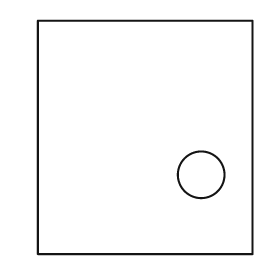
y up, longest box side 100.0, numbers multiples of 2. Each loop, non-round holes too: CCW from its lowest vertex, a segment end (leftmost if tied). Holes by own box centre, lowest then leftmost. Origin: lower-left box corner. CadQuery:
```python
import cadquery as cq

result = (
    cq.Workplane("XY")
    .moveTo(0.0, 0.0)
    .lineTo(92.0, 0.0)
    .lineTo(92.0, 100.0)
    .lineTo(0.0, 100.0)
    .close()
    .moveTo(70.0, 34.0)
    .circle(10.0)
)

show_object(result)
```